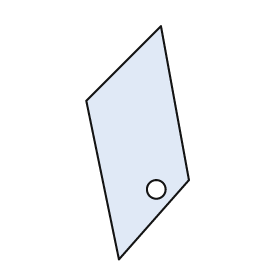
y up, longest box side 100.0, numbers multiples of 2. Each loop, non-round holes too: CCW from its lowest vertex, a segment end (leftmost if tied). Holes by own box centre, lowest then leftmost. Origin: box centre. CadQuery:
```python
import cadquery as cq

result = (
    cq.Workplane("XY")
    .moveTo(-8.0, -50.0)
    .lineTo(22.0, -16.0)
    .lineTo(10.0, 50.0)
    .lineTo(-22.0, 18.0)
    .close()
    .moveTo(8.0, -20.0)
    .circle(4.0)
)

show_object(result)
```